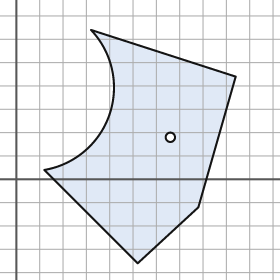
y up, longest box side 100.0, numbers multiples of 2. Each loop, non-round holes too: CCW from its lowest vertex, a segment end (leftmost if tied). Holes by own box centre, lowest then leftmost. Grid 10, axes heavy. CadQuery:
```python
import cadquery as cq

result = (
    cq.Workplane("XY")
    .moveTo(52.0, -36.0)
    .lineTo(78.0, -12.0)
    .lineTo(94.0, 44.0)
    .lineTo(32.0, 64.0)
    .threePointArc((40.0, 28.0), (12.0, 4.0))
    .close()
    .moveTo(66.0, 18.0)
    .circle(2.0)
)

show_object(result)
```